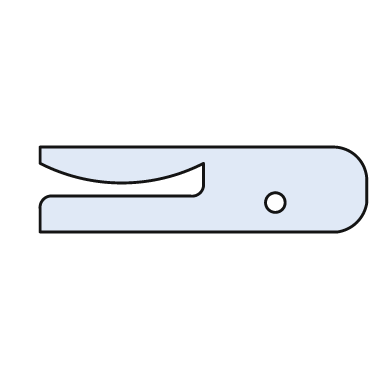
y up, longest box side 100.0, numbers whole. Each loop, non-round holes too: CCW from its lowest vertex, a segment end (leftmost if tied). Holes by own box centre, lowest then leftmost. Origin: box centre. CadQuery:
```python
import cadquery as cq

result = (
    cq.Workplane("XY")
    .moveTo(-50.0, -13.0)
    .lineTo(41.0, -13.0)
    .threePointArc((47.0, -10.0), (50.0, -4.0))
    .lineTo(50.0, 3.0)
    .threePointArc((47.0, 10.0), (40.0, 13.0))
    .lineTo(-50.0, 13.0)
    .lineTo(-50.0, 8.0)
    .threePointArc((-25.0, 2.0), (0.0, 8.0))
    .lineTo(0.0, 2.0)
    .threePointArc((-1.0, -1.0), (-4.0, -2.0))
    .lineTo(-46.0, -2.0)
    .threePointArc((-49.0, -3.0), (-50.0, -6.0))
    .close()
    .moveTo(22.0, -4.0)
    .circle(3.0)
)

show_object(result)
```